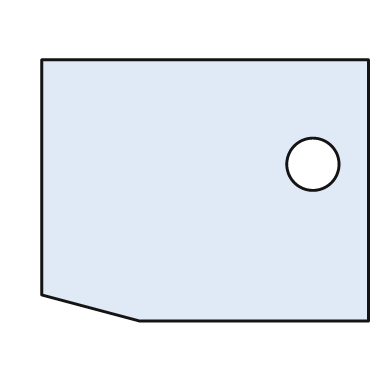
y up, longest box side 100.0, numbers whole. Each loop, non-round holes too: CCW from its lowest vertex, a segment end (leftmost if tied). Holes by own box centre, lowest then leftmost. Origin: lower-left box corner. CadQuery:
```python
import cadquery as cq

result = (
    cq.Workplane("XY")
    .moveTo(30.0, 0.0)
    .lineTo(100.0, 0.0)
    .lineTo(100.0, 80.0)
    .lineTo(0.0, 80.0)
    .lineTo(0.0, 8.0)
    .close()
    .moveTo(83.0, 48.0)
    .circle(8.0)
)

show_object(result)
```